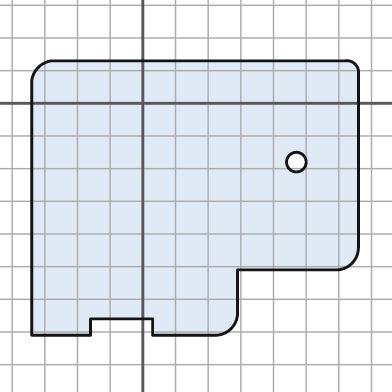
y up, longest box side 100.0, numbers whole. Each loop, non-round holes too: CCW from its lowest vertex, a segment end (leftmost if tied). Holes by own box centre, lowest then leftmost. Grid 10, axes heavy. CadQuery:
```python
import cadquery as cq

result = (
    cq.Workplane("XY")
    .moveTo(-34.0, -71.0)
    .lineTo(-16.0, -71.0)
    .lineTo(-16.0, -66.0)
    .lineTo(3.0, -66.0)
    .lineTo(3.0, -71.0)
    .lineTo(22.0, -71.0)
    .threePointArc((27.0, -69.0), (29.0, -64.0))
    .lineTo(29.0, -51.0)
    .lineTo(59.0, -51.0)
    .threePointArc((64.0, -49.0), (66.0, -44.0))
    .lineTo(66.0, 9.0)
    .threePointArc((65.0, 12.0), (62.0, 13.0))
    .lineTo(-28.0, 13.0)
    .threePointArc((-32.0, 11.0), (-34.0, 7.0))
    .close()
    .moveTo(47.0, -18.0)
    .circle(3.0)
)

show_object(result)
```